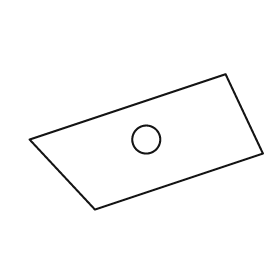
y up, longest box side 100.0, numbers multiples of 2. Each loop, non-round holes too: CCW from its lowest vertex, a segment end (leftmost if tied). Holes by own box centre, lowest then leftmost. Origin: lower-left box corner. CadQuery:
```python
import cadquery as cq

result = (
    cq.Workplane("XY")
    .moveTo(28.0, 0.0)
    .lineTo(100.0, 24.0)
    .lineTo(84.0, 58.0)
    .lineTo(0.0, 30.0)
    .close()
    .moveTo(50.0, 30.0)
    .circle(6.0)
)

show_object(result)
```